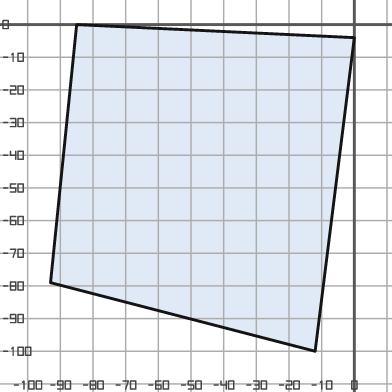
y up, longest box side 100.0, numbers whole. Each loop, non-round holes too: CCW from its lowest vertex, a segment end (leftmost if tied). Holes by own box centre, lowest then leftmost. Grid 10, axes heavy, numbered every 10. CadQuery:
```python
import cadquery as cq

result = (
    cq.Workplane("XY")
    .moveTo(-12.0, -100.0)
    .lineTo(0.0, -4.0)
    .lineTo(-85.0, 0.0)
    .lineTo(-93.0, -79.0)
    .close()
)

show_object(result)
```